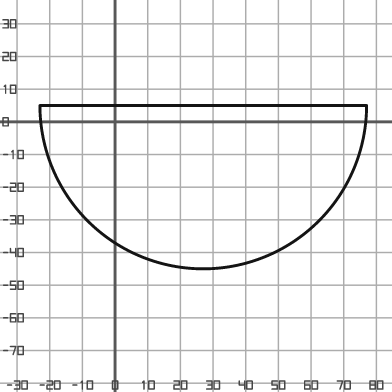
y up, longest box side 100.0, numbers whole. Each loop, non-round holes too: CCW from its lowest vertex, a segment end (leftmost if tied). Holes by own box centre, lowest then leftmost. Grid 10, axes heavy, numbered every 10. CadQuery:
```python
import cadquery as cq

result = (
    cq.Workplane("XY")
    .moveTo(-23.0, 5.0)
    .threePointArc((27.0, -45.0), (77.0, 5.0))
    .close()
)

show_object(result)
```